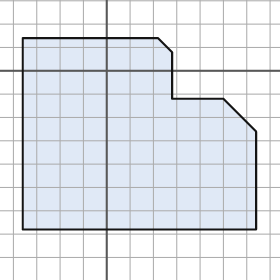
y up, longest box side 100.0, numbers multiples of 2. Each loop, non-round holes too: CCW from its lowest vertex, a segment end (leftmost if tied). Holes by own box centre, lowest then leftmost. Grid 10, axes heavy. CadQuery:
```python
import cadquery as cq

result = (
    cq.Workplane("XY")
    .moveTo(-36.0, -68.0)
    .lineTo(64.0, -68.0)
    .lineTo(64.0, -26.0)
    .lineTo(50.0, -12.0)
    .lineTo(28.0, -12.0)
    .lineTo(28.0, 8.0)
    .lineTo(22.0, 14.0)
    .lineTo(-36.0, 14.0)
    .close()
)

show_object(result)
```